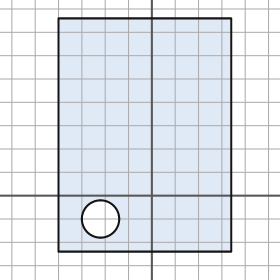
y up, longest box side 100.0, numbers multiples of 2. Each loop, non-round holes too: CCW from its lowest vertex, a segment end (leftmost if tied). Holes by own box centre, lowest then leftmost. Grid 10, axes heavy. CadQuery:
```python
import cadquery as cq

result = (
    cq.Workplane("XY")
    .moveTo(-40.0, -24.0)
    .lineTo(34.0, -24.0)
    .lineTo(34.0, 76.0)
    .lineTo(-40.0, 76.0)
    .close()
    .moveTo(-22.0, -10.0)
    .circle(8.0)
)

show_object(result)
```